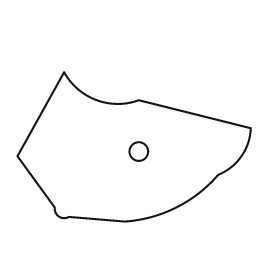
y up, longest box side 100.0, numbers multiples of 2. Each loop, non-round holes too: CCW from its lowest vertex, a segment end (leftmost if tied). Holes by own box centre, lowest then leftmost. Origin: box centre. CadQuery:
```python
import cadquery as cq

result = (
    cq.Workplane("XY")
    .moveTo(-4.0, -32.0)
    .threePointArc((18.0, -26.0), (36.0, -12.0))
    .threePointArc((46.0, -4.0), (50.0, 8.0))
    .lineTo(2.0, 20.0)
    .threePointArc((-16.0, 20.0), (-30.0, 32.0))
    .lineTo(-50.0, -4.0)
    .lineTo(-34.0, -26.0)
    .threePointArc((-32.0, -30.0), (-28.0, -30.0))
    .close()
    .moveTo(2.0, -2.0)
    .circle(4.0)
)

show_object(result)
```